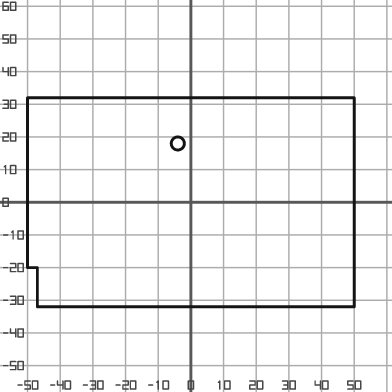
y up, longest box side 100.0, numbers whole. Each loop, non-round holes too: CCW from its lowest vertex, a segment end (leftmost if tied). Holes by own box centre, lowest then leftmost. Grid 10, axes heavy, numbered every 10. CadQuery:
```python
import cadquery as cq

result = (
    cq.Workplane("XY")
    .moveTo(-47.0, -32.0)
    .lineTo(50.0, -32.0)
    .lineTo(50.0, 32.0)
    .lineTo(-50.0, 32.0)
    .lineTo(-50.0, -20.0)
    .lineTo(-47.0, -20.0)
    .close()
    .moveTo(-4.0, 18.0)
    .circle(2.0)
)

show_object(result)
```